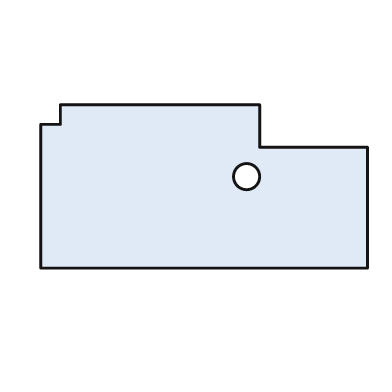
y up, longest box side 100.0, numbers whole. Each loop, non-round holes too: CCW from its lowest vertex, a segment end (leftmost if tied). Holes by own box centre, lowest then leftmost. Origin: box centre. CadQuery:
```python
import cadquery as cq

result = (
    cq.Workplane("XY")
    .moveTo(-50.0, -25.0)
    .lineTo(50.0, -25.0)
    .lineTo(50.0, 12.0)
    .lineTo(17.0, 12.0)
    .lineTo(17.0, 25.0)
    .lineTo(-44.0, 25.0)
    .lineTo(-44.0, 19.0)
    .lineTo(-50.0, 19.0)
    .close()
    .moveTo(13.0, 3.0)
    .circle(4.0)
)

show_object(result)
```